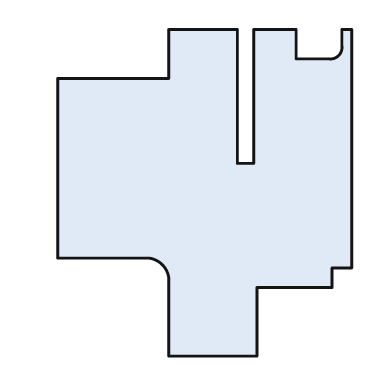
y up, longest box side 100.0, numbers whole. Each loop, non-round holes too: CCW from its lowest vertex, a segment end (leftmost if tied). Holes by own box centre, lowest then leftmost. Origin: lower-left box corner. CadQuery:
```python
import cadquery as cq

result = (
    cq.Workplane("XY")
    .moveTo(34.0, 0.0)
    .lineTo(61.0, 0.0)
    .lineTo(61.0, 21.0)
    .lineTo(84.0, 21.0)
    .lineTo(84.0, 27.0)
    .lineTo(90.0, 27.0)
    .lineTo(90.0, 100.0)
    .lineTo(87.0, 100.0)
    .lineTo(87.0, 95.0)
    .threePointArc((86.0, 92.0), (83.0, 91.0))
    .lineTo(73.0, 91.0)
    .lineTo(73.0, 100.0)
    .lineTo(60.0, 100.0)
    .lineTo(60.0, 59.0)
    .lineTo(55.0, 59.0)
    .lineTo(55.0, 100.0)
    .lineTo(34.0, 100.0)
    .lineTo(34.0, 85.0)
    .lineTo(0.0, 85.0)
    .lineTo(0.0, 30.0)
    .lineTo(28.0, 30.0)
    .threePointArc((32.0, 28.0), (34.0, 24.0))
    .close()
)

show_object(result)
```